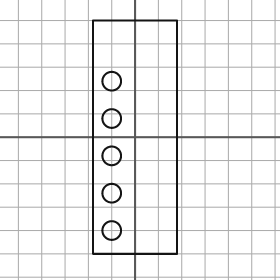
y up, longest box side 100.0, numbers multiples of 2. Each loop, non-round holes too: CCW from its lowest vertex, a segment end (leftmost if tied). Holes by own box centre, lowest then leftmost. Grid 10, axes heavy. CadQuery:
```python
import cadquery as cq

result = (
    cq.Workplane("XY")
    .moveTo(-18.0, -50.0)
    .lineTo(18.0, -50.0)
    .lineTo(18.0, 50.0)
    .lineTo(-18.0, 50.0)
    .close()
    .moveTo(-10.0, -40.0)
    .circle(4.0)
    .moveTo(-10.0, -24.0)
    .circle(4.0)
    .moveTo(-10.0, -8.0)
    .circle(4.0)
    .moveTo(-10.0, 8.0)
    .circle(4.0)
    .moveTo(-10.0, 24.0)
    .circle(4.0)
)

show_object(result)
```